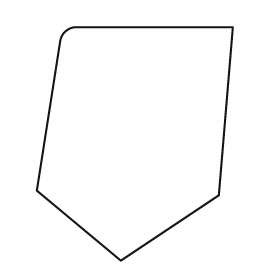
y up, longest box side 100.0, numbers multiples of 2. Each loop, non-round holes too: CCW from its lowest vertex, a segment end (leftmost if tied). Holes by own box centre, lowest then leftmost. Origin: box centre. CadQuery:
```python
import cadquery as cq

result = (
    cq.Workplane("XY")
    .moveTo(-6.0, -50.0)
    .lineTo(36.0, -22.0)
    .lineTo(42.0, 50.0)
    .lineTo(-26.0, 50.0)
    .threePointArc((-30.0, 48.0), (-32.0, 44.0))
    .lineTo(-42.0, -20.0)
    .close()
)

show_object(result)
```